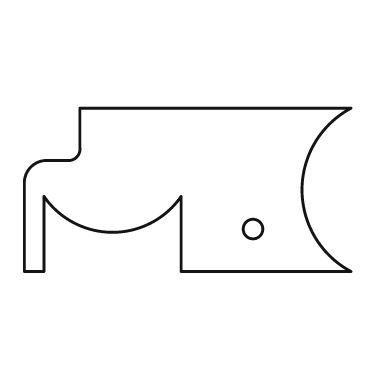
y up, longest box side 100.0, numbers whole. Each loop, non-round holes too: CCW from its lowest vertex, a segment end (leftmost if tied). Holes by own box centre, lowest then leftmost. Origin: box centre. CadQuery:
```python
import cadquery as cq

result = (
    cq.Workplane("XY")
    .moveTo(-50.0, -25.0)
    .lineTo(-44.0, -25.0)
    .lineTo(-44.0, -2.0)
    .threePointArc((-23.0, -13.0), (-2.0, -2.0))
    .lineTo(-2.0, -25.0)
    .lineTo(50.0, -25.0)
    .threePointArc((35.0, 0.0), (50.0, 25.0))
    .lineTo(-33.0, 25.0)
    .lineTo(-33.0, 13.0)
    .threePointArc((-34.0, 10.0), (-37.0, 9.0))
    .lineTo(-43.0, 9.0)
    .threePointArc((-48.0, 7.0), (-50.0, 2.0))
    .close()
    .moveTo(20.0, -12.0)
    .circle(3.0)
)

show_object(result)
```